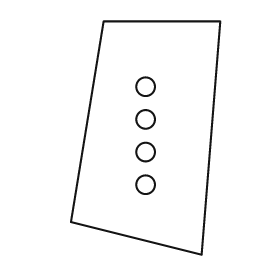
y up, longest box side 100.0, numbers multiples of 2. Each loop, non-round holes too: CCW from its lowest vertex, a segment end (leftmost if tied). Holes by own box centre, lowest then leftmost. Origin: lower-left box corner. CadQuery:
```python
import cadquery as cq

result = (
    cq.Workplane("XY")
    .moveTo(56.0, 0.0)
    .lineTo(64.0, 100.0)
    .lineTo(14.0, 100.0)
    .lineTo(0.0, 14.0)
    .close()
    .moveTo(32.0, 30.0)
    .circle(4.0)
    .moveTo(32.0, 44.0)
    .circle(4.0)
    .moveTo(32.0, 58.0)
    .circle(4.0)
    .moveTo(32.0, 72.0)
    .circle(4.0)
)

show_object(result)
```